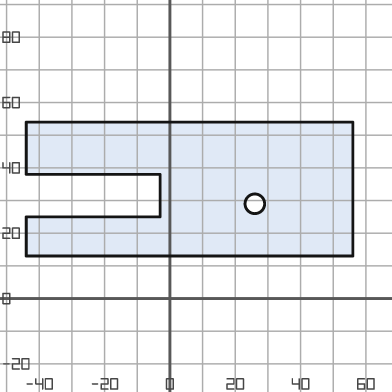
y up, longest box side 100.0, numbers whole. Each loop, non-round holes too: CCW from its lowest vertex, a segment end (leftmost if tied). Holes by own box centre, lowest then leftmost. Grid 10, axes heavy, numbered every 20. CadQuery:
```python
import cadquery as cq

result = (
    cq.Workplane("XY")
    .moveTo(-44.0, 13.0)
    .lineTo(56.0, 13.0)
    .lineTo(56.0, 54.0)
    .lineTo(-44.0, 54.0)
    .lineTo(-44.0, 38.0)
    .lineTo(-3.0, 38.0)
    .lineTo(-3.0, 25.0)
    .lineTo(-44.0, 25.0)
    .close()
    .moveTo(26.0, 29.0)
    .circle(3.0)
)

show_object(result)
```